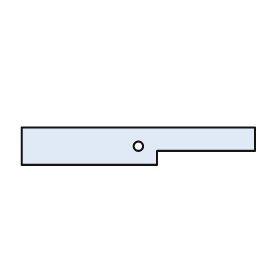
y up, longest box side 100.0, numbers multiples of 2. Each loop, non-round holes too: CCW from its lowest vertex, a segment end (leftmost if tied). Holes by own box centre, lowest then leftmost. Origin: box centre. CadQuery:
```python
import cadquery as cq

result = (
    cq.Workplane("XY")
    .moveTo(-50.0, -8.0)
    .lineTo(8.0, -8.0)
    .lineTo(8.0, -2.0)
    .lineTo(50.0, -2.0)
    .lineTo(50.0, 8.0)
    .lineTo(-50.0, 8.0)
    .close()
    .moveTo(0.0, 0.0)
    .circle(2.0)
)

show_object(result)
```